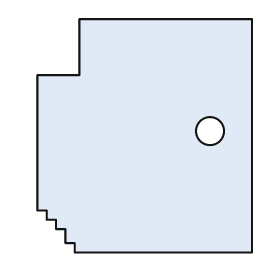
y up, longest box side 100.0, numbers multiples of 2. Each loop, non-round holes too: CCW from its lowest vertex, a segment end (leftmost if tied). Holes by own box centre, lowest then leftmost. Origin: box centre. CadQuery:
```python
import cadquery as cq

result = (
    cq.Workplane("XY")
    .moveTo(-30.0, -50.0)
    .lineTo(46.0, -50.0)
    .lineTo(46.0, 50.0)
    .lineTo(-28.0, 50.0)
    .lineTo(-28.0, 26.0)
    .lineTo(-46.0, 26.0)
    .lineTo(-46.0, -32.0)
    .lineTo(-42.0, -32.0)
    .lineTo(-42.0, -36.0)
    .lineTo(-38.0, -36.0)
    .lineTo(-38.0, -40.0)
    .lineTo(-34.0, -40.0)
    .lineTo(-34.0, -46.0)
    .lineTo(-30.0, -46.0)
    .close()
    .moveTo(28.0, 2.0)
    .circle(6.0)
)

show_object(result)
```